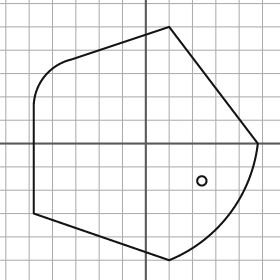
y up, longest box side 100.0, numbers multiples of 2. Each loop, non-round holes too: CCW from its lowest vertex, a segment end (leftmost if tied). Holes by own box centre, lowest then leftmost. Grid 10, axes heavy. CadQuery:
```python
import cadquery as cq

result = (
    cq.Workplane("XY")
    .moveTo(10.0, -50.0)
    .threePointArc((36.0, -30.0), (48.0, 0.0))
    .lineTo(10.0, 50.0)
    .lineTo(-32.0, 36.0)
    .threePointArc((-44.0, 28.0), (-48.0, 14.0))
    .lineTo(-48.0, -30.0)
    .close()
    .moveTo(24.0, -16.0)
    .circle(2.0)
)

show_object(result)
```